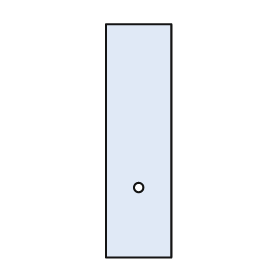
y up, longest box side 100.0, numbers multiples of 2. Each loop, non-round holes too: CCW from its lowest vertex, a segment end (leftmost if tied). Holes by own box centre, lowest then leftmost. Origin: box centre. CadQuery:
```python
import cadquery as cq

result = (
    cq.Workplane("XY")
    .moveTo(-14.0, -50.0)
    .lineTo(14.0, -50.0)
    .lineTo(14.0, 50.0)
    .lineTo(-14.0, 50.0)
    .close()
    .moveTo(0.0, -20.0)
    .circle(2.0)
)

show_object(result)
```